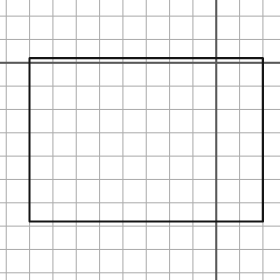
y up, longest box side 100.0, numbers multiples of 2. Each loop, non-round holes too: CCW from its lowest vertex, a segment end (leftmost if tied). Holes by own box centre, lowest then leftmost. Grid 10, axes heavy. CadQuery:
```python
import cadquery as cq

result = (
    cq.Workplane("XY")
    .moveTo(-80.0, -68.0)
    .lineTo(20.0, -68.0)
    .lineTo(20.0, 2.0)
    .lineTo(-80.0, 2.0)
    .close()
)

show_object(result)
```